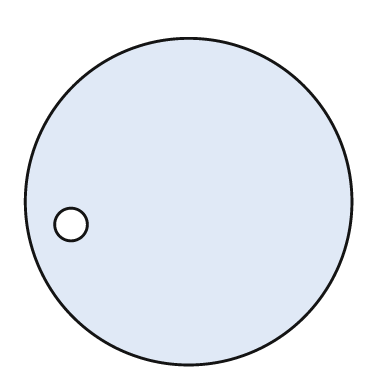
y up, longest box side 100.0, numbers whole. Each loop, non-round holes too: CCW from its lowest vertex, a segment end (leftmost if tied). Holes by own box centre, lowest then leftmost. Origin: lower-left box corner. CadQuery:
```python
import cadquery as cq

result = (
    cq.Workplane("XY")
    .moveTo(50.0, 50.0)
    .circle(50.0)
    .moveTo(14.0, 43.0)
    .circle(5.0)
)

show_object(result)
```